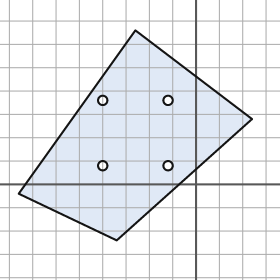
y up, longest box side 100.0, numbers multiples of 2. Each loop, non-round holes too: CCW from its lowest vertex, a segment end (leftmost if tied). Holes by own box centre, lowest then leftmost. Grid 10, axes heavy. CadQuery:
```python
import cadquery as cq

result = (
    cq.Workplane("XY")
    .moveTo(-34.0, -24.0)
    .lineTo(24.0, 28.0)
    .lineTo(-26.0, 66.0)
    .lineTo(-76.0, -4.0)
    .close()
    .moveTo(-40.0, 8.0)
    .circle(2.0)
    .moveTo(-12.0, 8.0)
    .circle(2.0)
    .moveTo(-40.0, 36.0)
    .circle(2.0)
    .moveTo(-12.0, 36.0)
    .circle(2.0)
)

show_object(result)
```